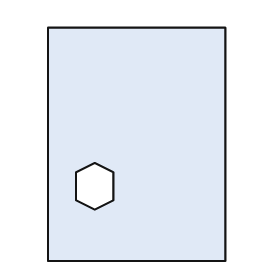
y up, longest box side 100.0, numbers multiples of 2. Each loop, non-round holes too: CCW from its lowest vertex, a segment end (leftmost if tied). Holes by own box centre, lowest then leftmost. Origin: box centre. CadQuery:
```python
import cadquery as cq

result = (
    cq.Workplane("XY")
    .moveTo(-38.0, -50.0)
    .lineTo(38.0, -50.0)
    .lineTo(38.0, 50.0)
    .lineTo(-38.0, 50.0)
    .close()
    .moveTo(-18.0, -28.0)
    .lineTo(-10.0, -24.0)
    .lineTo(-10.0, -12.0)
    .lineTo(-18.0, -8.0)
    .lineTo(-26.0, -12.0)
    .lineTo(-26.0, -24.0)
    .close()
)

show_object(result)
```